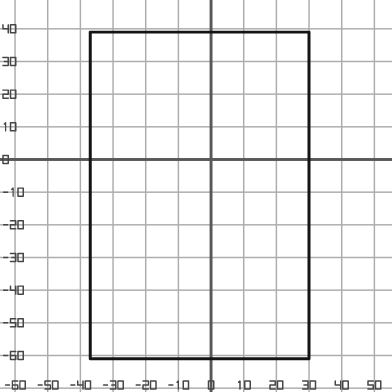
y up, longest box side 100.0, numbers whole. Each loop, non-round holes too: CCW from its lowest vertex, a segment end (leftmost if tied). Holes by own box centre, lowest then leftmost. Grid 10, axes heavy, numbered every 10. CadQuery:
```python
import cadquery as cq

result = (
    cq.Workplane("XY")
    .moveTo(-37.0, -61.0)
    .lineTo(30.0, -61.0)
    .lineTo(30.0, 39.0)
    .lineTo(-37.0, 39.0)
    .close()
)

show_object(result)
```